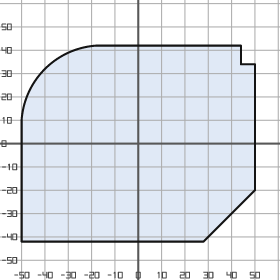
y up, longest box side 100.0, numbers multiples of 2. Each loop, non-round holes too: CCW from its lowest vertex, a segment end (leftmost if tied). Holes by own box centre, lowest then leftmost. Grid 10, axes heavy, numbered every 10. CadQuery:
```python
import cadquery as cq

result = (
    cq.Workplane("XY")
    .moveTo(-50.0, -42.0)
    .lineTo(28.0, -42.0)
    .lineTo(50.0, -20.0)
    .lineTo(50.0, 34.0)
    .lineTo(44.0, 34.0)
    .lineTo(44.0, 42.0)
    .lineTo(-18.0, 42.0)
    .threePointArc((-40.0, 32.0), (-50.0, 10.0))
    .close()
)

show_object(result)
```